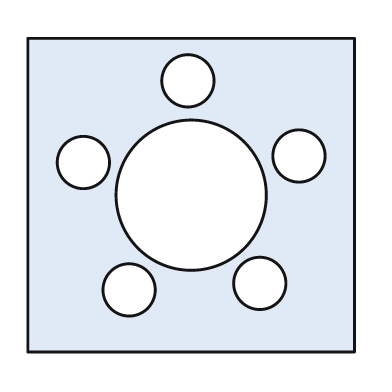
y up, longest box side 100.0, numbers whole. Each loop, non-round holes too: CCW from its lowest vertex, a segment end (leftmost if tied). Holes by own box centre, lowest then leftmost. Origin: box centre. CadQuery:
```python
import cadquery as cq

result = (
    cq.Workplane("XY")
    .moveTo(-50.0, -48.0)
    .lineTo(50.0, -48.0)
    .lineTo(50.0, 48.0)
    .lineTo(-50.0, 48.0)
    .close()
    .moveTo(-19.0, -29.0)
    .circle(8.0)
    .moveTo(21.0, -27.0)
    .circle(8.0)
    .moveTo(0.0, 0.0)
    .circle(23.0)
    .moveTo(-33.0, 10.0)
    .circle(8.0)
    .moveTo(33.0, 12.0)
    .circle(8.0)
    .moveTo(-1.0, 35.0)
    .circle(8.0)
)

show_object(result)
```